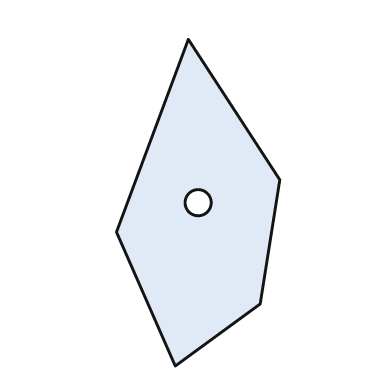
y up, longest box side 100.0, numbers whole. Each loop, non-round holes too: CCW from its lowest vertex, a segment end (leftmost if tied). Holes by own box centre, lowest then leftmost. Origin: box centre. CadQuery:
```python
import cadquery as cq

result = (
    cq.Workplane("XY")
    .moveTo(-7.0, -50.0)
    .lineTo(19.0, -31.0)
    .lineTo(25.0, 7.0)
    .lineTo(-3.0, 50.0)
    .lineTo(-25.0, -9.0)
    .close()
    .moveTo(0.0, 0.0)
    .circle(4.0)
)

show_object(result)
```